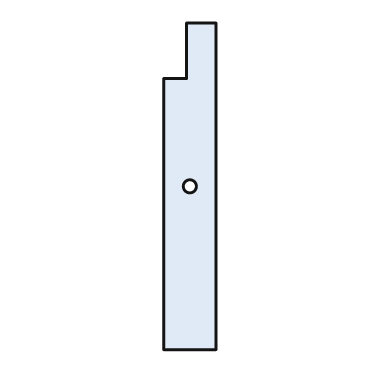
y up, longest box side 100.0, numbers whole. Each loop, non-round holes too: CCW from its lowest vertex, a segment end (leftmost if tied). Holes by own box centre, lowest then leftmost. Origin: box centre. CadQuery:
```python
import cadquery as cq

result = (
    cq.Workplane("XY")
    .moveTo(-8.0, -50.0)
    .lineTo(8.0, -50.0)
    .lineTo(8.0, 50.0)
    .lineTo(-1.0, 50.0)
    .lineTo(-1.0, 33.0)
    .lineTo(-8.0, 33.0)
    .close()
    .moveTo(0.0, 0.0)
    .circle(2.0)
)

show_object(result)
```